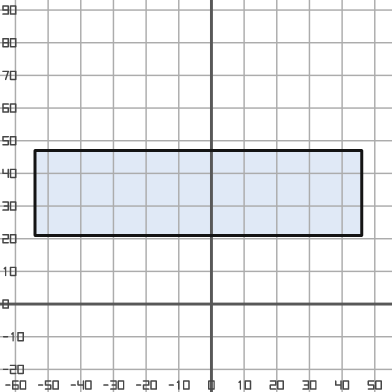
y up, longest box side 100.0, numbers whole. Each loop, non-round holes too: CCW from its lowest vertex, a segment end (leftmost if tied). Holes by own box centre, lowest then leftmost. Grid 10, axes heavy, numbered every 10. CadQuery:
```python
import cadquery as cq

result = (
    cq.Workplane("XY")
    .moveTo(-54.0, 21.0)
    .lineTo(46.0, 21.0)
    .lineTo(46.0, 47.0)
    .lineTo(-54.0, 47.0)
    .close()
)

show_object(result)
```